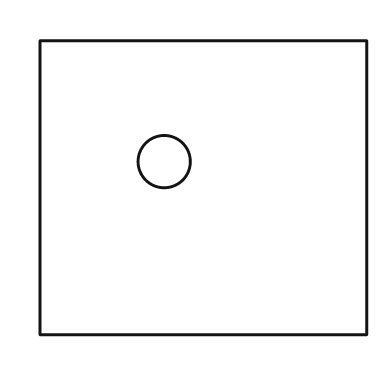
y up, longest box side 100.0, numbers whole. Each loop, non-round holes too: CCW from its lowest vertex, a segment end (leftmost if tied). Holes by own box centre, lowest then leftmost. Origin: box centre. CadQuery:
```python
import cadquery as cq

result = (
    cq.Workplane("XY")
    .moveTo(-50.0, -45.0)
    .lineTo(50.0, -45.0)
    .lineTo(50.0, 45.0)
    .lineTo(-50.0, 45.0)
    .close()
    .moveTo(-12.0, 8.0)
    .circle(8.0)
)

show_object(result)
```